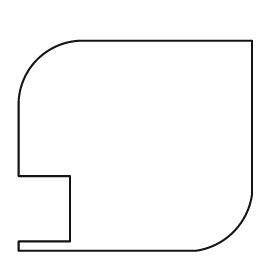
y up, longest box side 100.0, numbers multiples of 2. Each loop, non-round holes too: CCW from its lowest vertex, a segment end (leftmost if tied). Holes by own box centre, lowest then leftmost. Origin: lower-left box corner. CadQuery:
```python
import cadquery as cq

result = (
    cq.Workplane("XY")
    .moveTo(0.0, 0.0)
    .lineTo(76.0, 0.0)
    .threePointArc((92.0, 8.0), (100.0, 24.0))
    .lineTo(100.0, 90.0)
    .lineTo(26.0, 90.0)
    .threePointArc((8.0, 82.0), (0.0, 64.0))
    .lineTo(0.0, 32.0)
    .lineTo(22.0, 32.0)
    .lineTo(22.0, 4.0)
    .lineTo(0.0, 4.0)
    .close()
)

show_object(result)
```